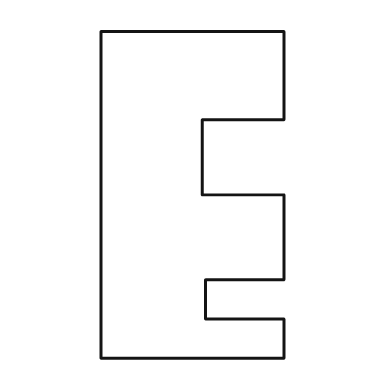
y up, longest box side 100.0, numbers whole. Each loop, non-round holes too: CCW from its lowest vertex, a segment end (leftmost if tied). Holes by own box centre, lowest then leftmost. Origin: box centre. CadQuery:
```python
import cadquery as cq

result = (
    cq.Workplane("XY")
    .moveTo(-28.0, -50.0)
    .lineTo(28.0, -50.0)
    .lineTo(28.0, -38.0)
    .lineTo(4.0, -38.0)
    .lineTo(4.0, -26.0)
    .lineTo(28.0, -26.0)
    .lineTo(28.0, 0.0)
    .lineTo(3.0, 0.0)
    .lineTo(3.0, 23.0)
    .lineTo(28.0, 23.0)
    .lineTo(28.0, 50.0)
    .lineTo(-28.0, 50.0)
    .close()
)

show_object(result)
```